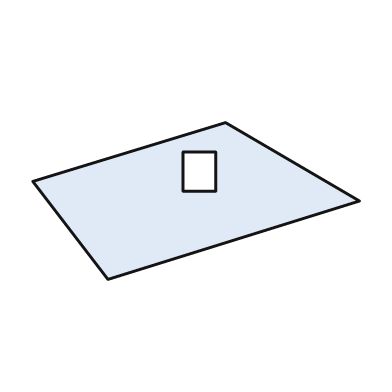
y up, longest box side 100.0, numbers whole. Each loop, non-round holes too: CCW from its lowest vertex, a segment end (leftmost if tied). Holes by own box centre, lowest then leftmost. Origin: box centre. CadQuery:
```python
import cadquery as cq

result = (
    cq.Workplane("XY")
    .moveTo(-27.0, -24.0)
    .lineTo(50.0, 0.0)
    .lineTo(9.0, 24.0)
    .lineTo(-50.0, 6.0)
    .close()
    .moveTo(-4.0, 3.0)
    .lineTo(6.0, 3.0)
    .lineTo(6.0, 15.0)
    .lineTo(-4.0, 15.0)
    .close()
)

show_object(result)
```